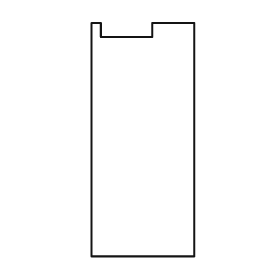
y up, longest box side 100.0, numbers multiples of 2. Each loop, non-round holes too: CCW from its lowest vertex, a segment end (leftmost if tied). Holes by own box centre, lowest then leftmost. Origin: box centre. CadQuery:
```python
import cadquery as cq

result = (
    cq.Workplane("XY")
    .moveTo(-22.0, -50.0)
    .lineTo(22.0, -50.0)
    .lineTo(22.0, 50.0)
    .lineTo(4.0, 50.0)
    .lineTo(4.0, 44.0)
    .lineTo(-18.0, 44.0)
    .lineTo(-18.0, 50.0)
    .lineTo(-22.0, 50.0)
    .close()
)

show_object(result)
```